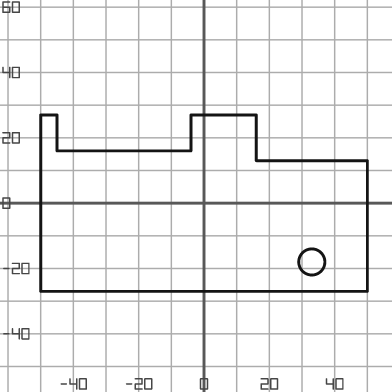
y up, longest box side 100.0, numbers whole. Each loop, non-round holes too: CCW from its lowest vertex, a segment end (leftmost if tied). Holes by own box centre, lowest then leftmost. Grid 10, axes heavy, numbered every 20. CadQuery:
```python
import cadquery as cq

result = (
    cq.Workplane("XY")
    .moveTo(-50.0, -27.0)
    .lineTo(50.0, -27.0)
    .lineTo(50.0, 13.0)
    .lineTo(16.0, 13.0)
    .lineTo(16.0, 27.0)
    .lineTo(-4.0, 27.0)
    .lineTo(-4.0, 16.0)
    .lineTo(-45.0, 16.0)
    .lineTo(-45.0, 27.0)
    .lineTo(-50.0, 27.0)
    .close()
    .moveTo(33.0, -18.0)
    .circle(4.0)
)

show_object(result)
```